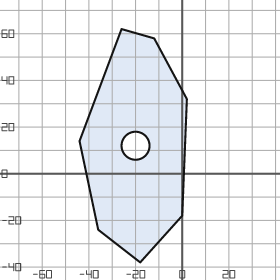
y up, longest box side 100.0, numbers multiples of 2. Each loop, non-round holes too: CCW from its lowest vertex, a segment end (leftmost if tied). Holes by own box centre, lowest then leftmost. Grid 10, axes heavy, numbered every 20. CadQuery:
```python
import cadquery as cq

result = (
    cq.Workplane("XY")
    .moveTo(-18.0, -38.0)
    .lineTo(0.0, -18.0)
    .lineTo(2.0, 32.0)
    .lineTo(-12.0, 58.0)
    .lineTo(-26.0, 62.0)
    .lineTo(-44.0, 14.0)
    .lineTo(-36.0, -24.0)
    .close()
    .moveTo(-20.0, 12.0)
    .circle(6.0)
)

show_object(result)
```